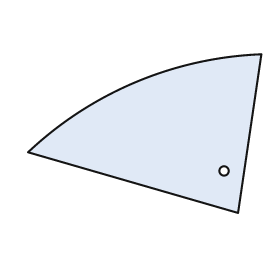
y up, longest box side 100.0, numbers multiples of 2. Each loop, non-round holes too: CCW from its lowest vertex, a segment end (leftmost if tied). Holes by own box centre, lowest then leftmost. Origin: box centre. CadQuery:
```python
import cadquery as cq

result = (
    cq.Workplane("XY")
    .moveTo(40.0, -34.0)
    .lineTo(50.0, 34.0)
    .threePointArc((-4.0, 22.0), (-50.0, -8.0))
    .close()
    .moveTo(34.0, -16.0)
    .circle(2.0)
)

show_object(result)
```